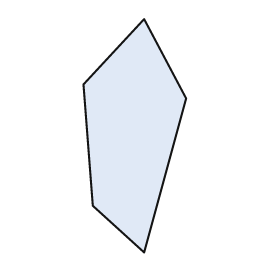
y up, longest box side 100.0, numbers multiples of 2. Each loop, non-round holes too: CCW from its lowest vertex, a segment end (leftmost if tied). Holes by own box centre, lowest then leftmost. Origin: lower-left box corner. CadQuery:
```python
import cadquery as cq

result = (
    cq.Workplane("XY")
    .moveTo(26.0, 0.0)
    .lineTo(44.0, 66.0)
    .lineTo(26.0, 100.0)
    .lineTo(0.0, 72.0)
    .lineTo(4.0, 20.0)
    .close()
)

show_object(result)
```